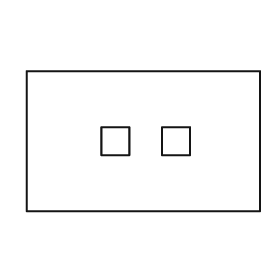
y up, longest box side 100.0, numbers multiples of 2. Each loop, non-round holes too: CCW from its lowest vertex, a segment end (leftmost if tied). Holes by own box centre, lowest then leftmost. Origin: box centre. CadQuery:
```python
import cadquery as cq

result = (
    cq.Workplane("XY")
    .moveTo(-50.0, -30.0)
    .lineTo(50.0, -30.0)
    .lineTo(50.0, 30.0)
    .lineTo(-50.0, 30.0)
    .close()
    .moveTo(-18.0, -6.0)
    .lineTo(-6.0, -6.0)
    .lineTo(-6.0, 6.0)
    .lineTo(-18.0, 6.0)
    .close()
    .moveTo(8.0, -6.0)
    .lineTo(20.0, -6.0)
    .lineTo(20.0, 6.0)
    .lineTo(8.0, 6.0)
    .close()
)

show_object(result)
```